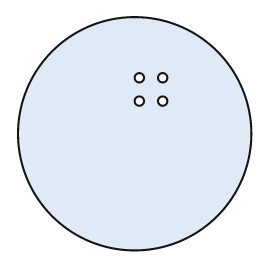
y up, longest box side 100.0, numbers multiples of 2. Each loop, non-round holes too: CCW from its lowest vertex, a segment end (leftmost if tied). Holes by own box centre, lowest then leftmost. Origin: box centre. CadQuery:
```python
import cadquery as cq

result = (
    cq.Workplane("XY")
    .moveTo(0.0, 0.0)
    .circle(50.0)
    .moveTo(2.0, 14.0)
    .circle(2.0)
    .moveTo(12.0, 14.0)
    .circle(2.0)
    .moveTo(2.0, 24.0)
    .circle(2.0)
    .moveTo(12.0, 24.0)
    .circle(2.0)
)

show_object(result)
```